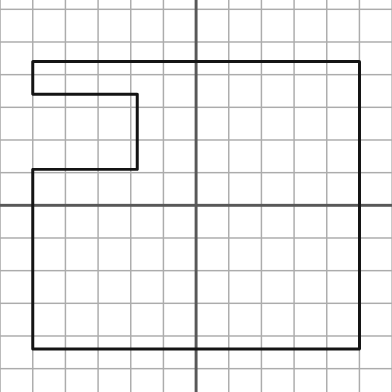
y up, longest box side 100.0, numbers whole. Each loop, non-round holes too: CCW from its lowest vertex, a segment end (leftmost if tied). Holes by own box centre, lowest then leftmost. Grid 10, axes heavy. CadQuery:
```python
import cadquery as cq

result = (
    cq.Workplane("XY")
    .moveTo(-50.0, -44.0)
    .lineTo(50.0, -44.0)
    .lineTo(50.0, 44.0)
    .lineTo(-50.0, 44.0)
    .lineTo(-50.0, 34.0)
    .lineTo(-18.0, 34.0)
    .lineTo(-18.0, 11.0)
    .lineTo(-50.0, 11.0)
    .close()
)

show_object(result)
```